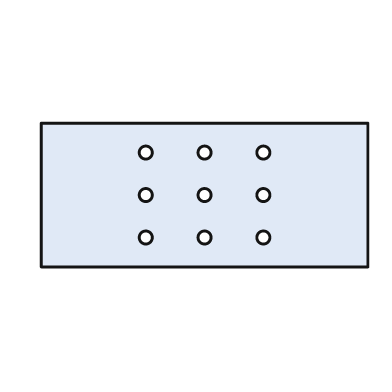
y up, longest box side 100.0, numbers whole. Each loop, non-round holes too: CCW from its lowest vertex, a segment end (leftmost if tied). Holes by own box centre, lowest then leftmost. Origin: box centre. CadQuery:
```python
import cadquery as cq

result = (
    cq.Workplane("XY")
    .moveTo(-50.0, -22.0)
    .lineTo(50.0, -22.0)
    .lineTo(50.0, 22.0)
    .lineTo(-50.0, 22.0)
    .close()
    .moveTo(-18.0, -13.0)
    .circle(2.0)
    .moveTo(0.0, -13.0)
    .circle(2.0)
    .moveTo(18.0, -13.0)
    .circle(2.0)
    .moveTo(-18.0, 0.0)
    .circle(2.0)
    .moveTo(0.0, 0.0)
    .circle(2.0)
    .moveTo(18.0, 0.0)
    .circle(2.0)
    .moveTo(-18.0, 13.0)
    .circle(2.0)
    .moveTo(0.0, 13.0)
    .circle(2.0)
    .moveTo(18.0, 13.0)
    .circle(2.0)
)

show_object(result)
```